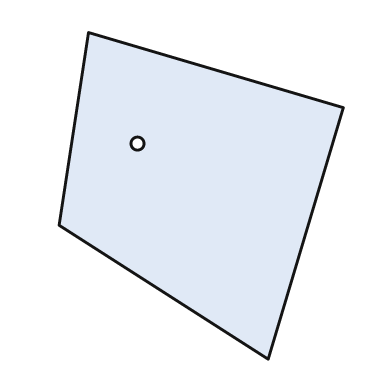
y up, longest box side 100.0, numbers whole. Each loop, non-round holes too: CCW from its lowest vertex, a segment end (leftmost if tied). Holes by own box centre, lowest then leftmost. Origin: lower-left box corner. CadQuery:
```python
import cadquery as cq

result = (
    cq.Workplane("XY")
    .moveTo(64.0, 0.0)
    .lineTo(87.0, 77.0)
    .lineTo(9.0, 100.0)
    .lineTo(0.0, 41.0)
    .close()
    .moveTo(24.0, 66.0)
    .circle(2.0)
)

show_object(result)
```